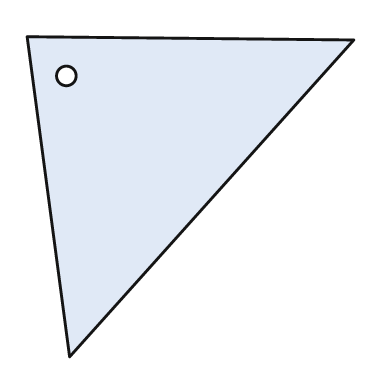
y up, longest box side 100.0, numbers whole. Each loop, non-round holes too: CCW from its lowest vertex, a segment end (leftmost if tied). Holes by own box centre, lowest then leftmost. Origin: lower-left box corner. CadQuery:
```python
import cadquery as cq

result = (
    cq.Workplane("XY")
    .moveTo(13.0, 0.0)
    .lineTo(100.0, 97.0)
    .lineTo(0.0, 98.0)
    .close()
    .moveTo(12.0, 86.0)
    .circle(3.0)
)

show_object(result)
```